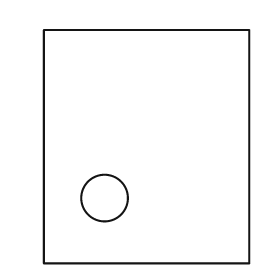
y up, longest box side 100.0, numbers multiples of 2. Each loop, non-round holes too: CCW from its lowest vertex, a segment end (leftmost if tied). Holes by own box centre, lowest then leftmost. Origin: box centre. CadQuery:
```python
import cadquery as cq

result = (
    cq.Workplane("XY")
    .moveTo(-44.0, -50.0)
    .lineTo(44.0, -50.0)
    .lineTo(44.0, 50.0)
    .lineTo(-44.0, 50.0)
    .close()
    .moveTo(-18.0, -22.0)
    .circle(10.0)
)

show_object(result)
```